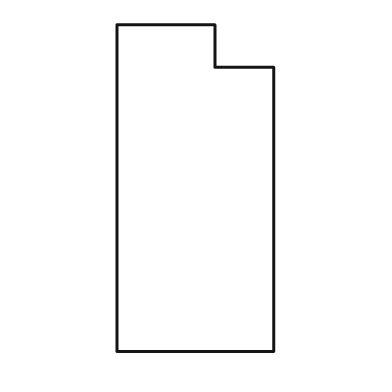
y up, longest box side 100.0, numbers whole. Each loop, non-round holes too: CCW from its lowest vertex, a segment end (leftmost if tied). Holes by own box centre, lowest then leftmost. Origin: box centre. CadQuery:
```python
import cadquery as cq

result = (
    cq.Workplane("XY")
    .moveTo(-24.0, -50.0)
    .lineTo(24.0, -50.0)
    .lineTo(24.0, 37.0)
    .lineTo(6.0, 37.0)
    .lineTo(6.0, 50.0)
    .lineTo(-24.0, 50.0)
    .close()
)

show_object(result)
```